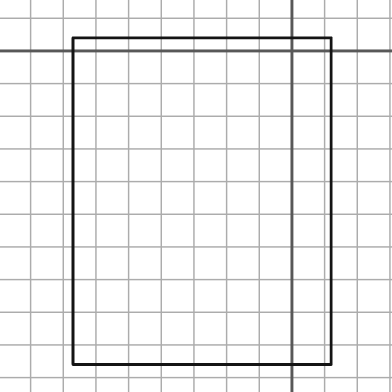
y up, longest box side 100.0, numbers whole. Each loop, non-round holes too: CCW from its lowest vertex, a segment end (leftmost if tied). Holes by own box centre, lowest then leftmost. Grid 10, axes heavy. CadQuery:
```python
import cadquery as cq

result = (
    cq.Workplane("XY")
    .moveTo(-67.0, -96.0)
    .lineTo(12.0, -96.0)
    .lineTo(12.0, 4.0)
    .lineTo(-67.0, 4.0)
    .close()
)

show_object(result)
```